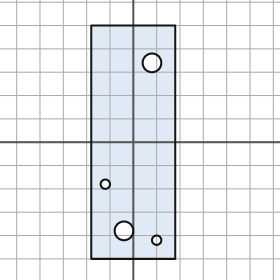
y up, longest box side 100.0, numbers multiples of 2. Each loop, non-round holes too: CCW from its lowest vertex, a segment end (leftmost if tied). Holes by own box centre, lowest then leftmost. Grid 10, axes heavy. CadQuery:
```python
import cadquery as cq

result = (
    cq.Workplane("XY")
    .moveTo(-18.0, -50.0)
    .lineTo(18.0, -50.0)
    .lineTo(18.0, 50.0)
    .lineTo(-18.0, 50.0)
    .close()
    .moveTo(10.0, -42.0)
    .circle(2.0)
    .moveTo(-4.0, -38.0)
    .circle(4.0)
    .moveTo(-12.0, -18.0)
    .circle(2.0)
    .moveTo(8.0, 34.0)
    .circle(4.0)
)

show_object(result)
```